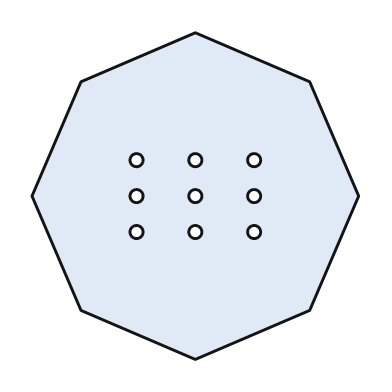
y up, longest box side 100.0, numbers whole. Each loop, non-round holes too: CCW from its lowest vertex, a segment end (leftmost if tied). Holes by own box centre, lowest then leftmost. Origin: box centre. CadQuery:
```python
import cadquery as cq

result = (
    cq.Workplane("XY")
    .moveTo(0.0, -50.0)
    .lineTo(35.0, -35.0)
    .lineTo(50.0, 0.0)
    .lineTo(35.0, 35.0)
    .lineTo(0.0, 50.0)
    .lineTo(-35.0, 35.0)
    .lineTo(-50.0, 0.0)
    .lineTo(-35.0, -35.0)
    .close()
    .moveTo(-18.0, -11.0)
    .circle(2.0)
    .moveTo(0.0, -11.0)
    .circle(2.0)
    .moveTo(18.0, -11.0)
    .circle(2.0)
    .moveTo(-18.0, 0.0)
    .circle(2.0)
    .moveTo(0.0, 0.0)
    .circle(2.0)
    .moveTo(18.0, 0.0)
    .circle(2.0)
    .moveTo(-18.0, 11.0)
    .circle(2.0)
    .moveTo(0.0, 11.0)
    .circle(2.0)
    .moveTo(18.0, 11.0)
    .circle(2.0)
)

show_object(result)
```